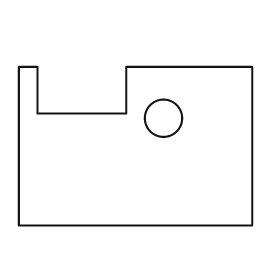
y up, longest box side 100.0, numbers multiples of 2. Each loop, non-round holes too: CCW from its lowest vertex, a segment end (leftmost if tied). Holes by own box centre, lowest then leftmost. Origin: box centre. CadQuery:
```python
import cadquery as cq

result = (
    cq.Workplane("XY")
    .moveTo(-50.0, -34.0)
    .lineTo(50.0, -34.0)
    .lineTo(50.0, 34.0)
    .lineTo(-4.0, 34.0)
    .lineTo(-4.0, 14.0)
    .lineTo(-42.0, 14.0)
    .lineTo(-42.0, 34.0)
    .lineTo(-50.0, 34.0)
    .close()
    .moveTo(12.0, 12.0)
    .circle(8.0)
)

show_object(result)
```